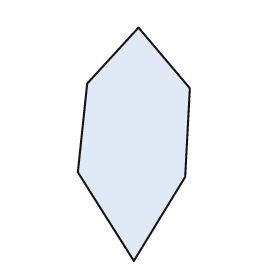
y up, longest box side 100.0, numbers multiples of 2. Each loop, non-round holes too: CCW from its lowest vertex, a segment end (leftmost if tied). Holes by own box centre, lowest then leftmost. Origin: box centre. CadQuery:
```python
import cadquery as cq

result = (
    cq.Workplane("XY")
    .moveTo(0.0, -50.0)
    .lineTo(22.0, -14.0)
    .lineTo(24.0, 24.0)
    .lineTo(2.0, 50.0)
    .lineTo(-20.0, 26.0)
    .lineTo(-24.0, -12.0)
    .close()
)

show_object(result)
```